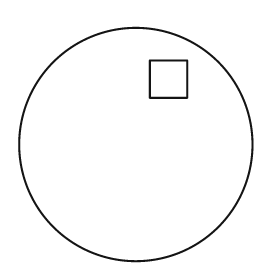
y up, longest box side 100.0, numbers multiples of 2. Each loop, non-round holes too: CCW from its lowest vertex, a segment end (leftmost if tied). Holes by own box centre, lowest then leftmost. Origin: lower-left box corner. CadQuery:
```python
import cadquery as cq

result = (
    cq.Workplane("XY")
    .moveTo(50.0, 50.0)
    .circle(50.0)
    .moveTo(56.0, 70.0)
    .lineTo(72.0, 70.0)
    .lineTo(72.0, 86.0)
    .lineTo(56.0, 86.0)
    .close()
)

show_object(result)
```